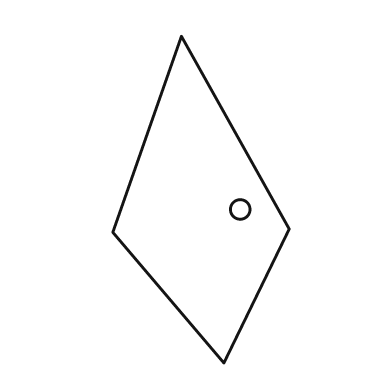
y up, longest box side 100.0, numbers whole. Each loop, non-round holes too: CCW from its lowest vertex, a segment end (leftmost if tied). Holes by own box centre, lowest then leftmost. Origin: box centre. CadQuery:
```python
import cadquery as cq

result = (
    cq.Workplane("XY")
    .moveTo(7.0, -50.0)
    .lineTo(27.0, -9.0)
    .lineTo(-6.0, 50.0)
    .lineTo(-27.0, -10.0)
    .close()
    .moveTo(12.0, -3.0)
    .circle(3.0)
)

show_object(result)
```